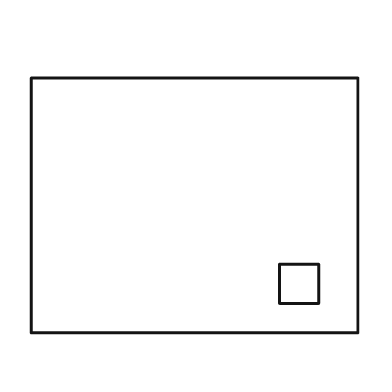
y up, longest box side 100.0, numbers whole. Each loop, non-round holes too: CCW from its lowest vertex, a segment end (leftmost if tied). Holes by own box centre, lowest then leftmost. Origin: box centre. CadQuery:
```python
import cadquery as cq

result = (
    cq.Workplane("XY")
    .moveTo(-50.0, -39.0)
    .lineTo(50.0, -39.0)
    .lineTo(50.0, 39.0)
    .lineTo(-50.0, 39.0)
    .close()
    .moveTo(26.0, -30.0)
    .lineTo(38.0, -30.0)
    .lineTo(38.0, -18.0)
    .lineTo(26.0, -18.0)
    .close()
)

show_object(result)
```